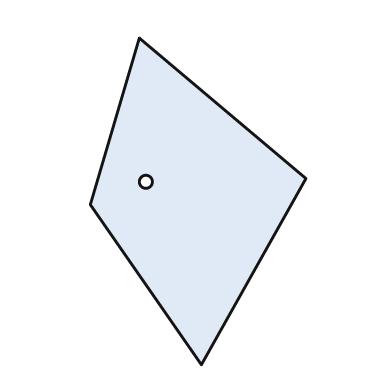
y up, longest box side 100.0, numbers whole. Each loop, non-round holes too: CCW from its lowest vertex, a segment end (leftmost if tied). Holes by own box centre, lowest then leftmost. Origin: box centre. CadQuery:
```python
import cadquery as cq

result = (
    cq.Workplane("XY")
    .moveTo(1.0, -50.0)
    .lineTo(33.0, 7.0)
    .lineTo(-18.0, 50.0)
    .lineTo(-33.0, -1.0)
    .close()
    .moveTo(-16.0, 6.0)
    .circle(2.0)
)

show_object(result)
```